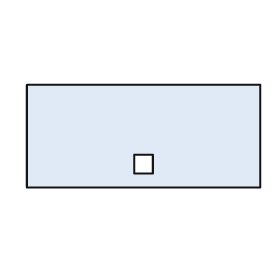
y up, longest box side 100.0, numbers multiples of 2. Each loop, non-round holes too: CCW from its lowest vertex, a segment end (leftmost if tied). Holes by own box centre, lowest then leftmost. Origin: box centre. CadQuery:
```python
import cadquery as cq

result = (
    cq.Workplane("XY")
    .moveTo(-50.0, -22.0)
    .lineTo(50.0, -22.0)
    .lineTo(50.0, 22.0)
    .lineTo(-50.0, 22.0)
    .close()
    .moveTo(-4.0, -16.0)
    .lineTo(4.0, -16.0)
    .lineTo(4.0, -8.0)
    .lineTo(-4.0, -8.0)
    .close()
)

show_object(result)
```